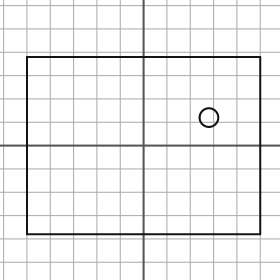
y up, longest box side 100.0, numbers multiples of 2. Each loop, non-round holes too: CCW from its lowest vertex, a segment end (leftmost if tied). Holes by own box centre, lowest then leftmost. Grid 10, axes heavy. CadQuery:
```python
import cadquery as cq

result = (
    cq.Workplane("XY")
    .moveTo(-50.0, -38.0)
    .lineTo(50.0, -38.0)
    .lineTo(50.0, 38.0)
    .lineTo(-50.0, 38.0)
    .close()
    .moveTo(28.0, 12.0)
    .circle(4.0)
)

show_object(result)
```